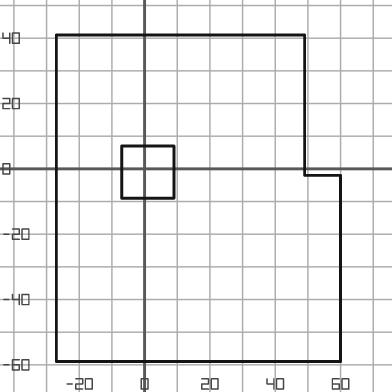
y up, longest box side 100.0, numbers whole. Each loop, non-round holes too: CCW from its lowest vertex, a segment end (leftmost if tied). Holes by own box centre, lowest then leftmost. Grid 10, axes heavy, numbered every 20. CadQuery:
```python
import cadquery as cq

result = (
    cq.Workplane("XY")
    .moveTo(-27.0, -59.0)
    .lineTo(60.0, -59.0)
    .lineTo(60.0, -2.0)
    .lineTo(49.0, -2.0)
    .lineTo(49.0, 41.0)
    .lineTo(-27.0, 41.0)
    .close()
    .moveTo(-7.0, -9.0)
    .lineTo(9.0, -9.0)
    .lineTo(9.0, 7.0)
    .lineTo(-7.0, 7.0)
    .close()
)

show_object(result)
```